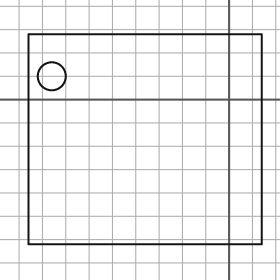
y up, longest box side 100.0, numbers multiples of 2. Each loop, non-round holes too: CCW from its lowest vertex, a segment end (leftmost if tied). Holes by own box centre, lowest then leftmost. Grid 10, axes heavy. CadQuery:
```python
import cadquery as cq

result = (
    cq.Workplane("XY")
    .moveTo(-86.0, -62.0)
    .lineTo(14.0, -62.0)
    .lineTo(14.0, 28.0)
    .lineTo(-86.0, 28.0)
    .close()
    .moveTo(-76.0, 10.0)
    .circle(6.0)
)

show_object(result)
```